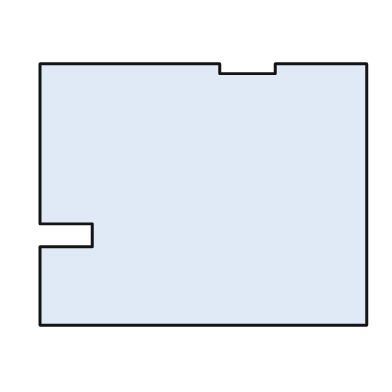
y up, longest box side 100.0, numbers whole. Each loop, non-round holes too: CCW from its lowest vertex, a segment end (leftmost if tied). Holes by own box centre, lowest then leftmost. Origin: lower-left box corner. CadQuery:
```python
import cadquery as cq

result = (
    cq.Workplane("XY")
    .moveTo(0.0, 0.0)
    .lineTo(100.0, 0.0)
    .lineTo(100.0, 80.0)
    .lineTo(72.0, 80.0)
    .lineTo(72.0, 77.0)
    .lineTo(55.0, 77.0)
    .lineTo(55.0, 80.0)
    .lineTo(0.0, 80.0)
    .lineTo(0.0, 31.0)
    .lineTo(16.0, 31.0)
    .lineTo(16.0, 24.0)
    .lineTo(0.0, 24.0)
    .close()
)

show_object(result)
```